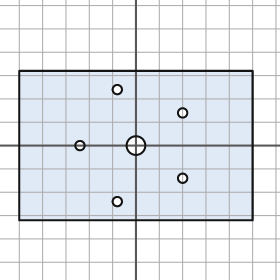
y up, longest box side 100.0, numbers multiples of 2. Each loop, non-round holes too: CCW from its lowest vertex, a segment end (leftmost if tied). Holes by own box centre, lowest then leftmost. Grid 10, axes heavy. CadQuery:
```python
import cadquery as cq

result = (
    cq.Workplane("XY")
    .moveTo(-50.0, -32.0)
    .lineTo(50.0, -32.0)
    .lineTo(50.0, 32.0)
    .lineTo(-50.0, 32.0)
    .close()
    .moveTo(-8.0, -24.0)
    .circle(2.0)
    .moveTo(20.0, -14.0)
    .circle(2.0)
    .moveTo(-24.0, 0.0)
    .circle(2.0)
    .moveTo(0.0, 0.0)
    .circle(4.0)
    .moveTo(20.0, 14.0)
    .circle(2.0)
    .moveTo(-8.0, 24.0)
    .circle(2.0)
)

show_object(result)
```